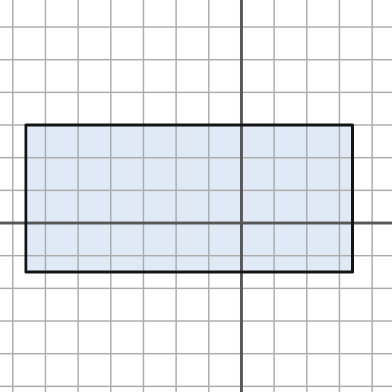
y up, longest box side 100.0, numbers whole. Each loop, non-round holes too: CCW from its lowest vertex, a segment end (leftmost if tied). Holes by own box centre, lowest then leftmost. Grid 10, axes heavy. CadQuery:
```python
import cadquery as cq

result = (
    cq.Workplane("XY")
    .moveTo(-66.0, -15.0)
    .lineTo(34.0, -15.0)
    .lineTo(34.0, 30.0)
    .lineTo(-66.0, 30.0)
    .close()
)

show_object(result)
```